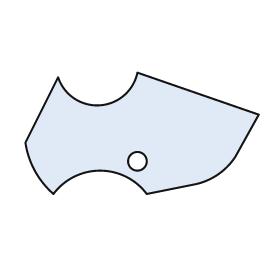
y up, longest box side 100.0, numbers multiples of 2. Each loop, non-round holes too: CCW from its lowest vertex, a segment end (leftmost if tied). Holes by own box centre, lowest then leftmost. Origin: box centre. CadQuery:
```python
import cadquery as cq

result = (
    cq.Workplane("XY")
    .moveTo(-38.0, -26.0)
    .threePointArc((-18.0, -16.0), (2.0, -26.0))
    .lineTo(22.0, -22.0)
    .threePointArc((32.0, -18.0), (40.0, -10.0))
    .lineTo(50.0, 8.0)
    .lineTo(-2.0, 26.0)
    .threePointArc((-18.0, 12.0), (-36.0, 24.0))
    .lineTo(-50.0, -4.0)
    .threePointArc((-46.0, -16.0), (-38.0, -26.0))
    .close()
    .moveTo(-2.0, -12.0)
    .circle(4.0)
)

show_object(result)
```